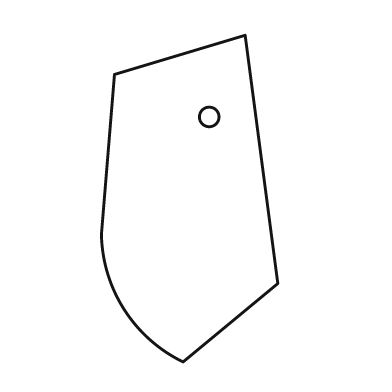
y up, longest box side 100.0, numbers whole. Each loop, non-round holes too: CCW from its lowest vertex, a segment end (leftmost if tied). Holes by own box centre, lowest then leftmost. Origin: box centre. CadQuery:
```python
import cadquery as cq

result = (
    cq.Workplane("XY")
    .moveTo(-2.0, -50.0)
    .lineTo(27.0, -26.0)
    .lineTo(17.0, 50.0)
    .lineTo(-23.0, 38.0)
    .lineTo(-27.0, -11.0)
    .threePointArc((-20.0, -34.0), (-2.0, -50.0))
    .close()
    .moveTo(6.0, 25.0)
    .circle(3.0)
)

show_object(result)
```